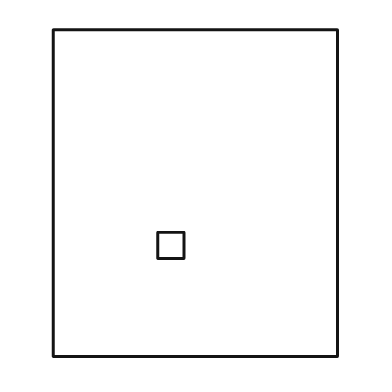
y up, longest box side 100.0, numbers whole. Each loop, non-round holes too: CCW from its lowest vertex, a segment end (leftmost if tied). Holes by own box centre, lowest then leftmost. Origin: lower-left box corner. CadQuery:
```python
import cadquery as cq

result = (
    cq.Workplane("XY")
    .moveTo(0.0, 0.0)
    .lineTo(87.0, 0.0)
    .lineTo(87.0, 100.0)
    .lineTo(0.0, 100.0)
    .close()
    .moveTo(32.0, 30.0)
    .lineTo(40.0, 30.0)
    .lineTo(40.0, 38.0)
    .lineTo(32.0, 38.0)
    .close()
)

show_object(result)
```